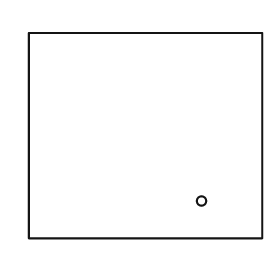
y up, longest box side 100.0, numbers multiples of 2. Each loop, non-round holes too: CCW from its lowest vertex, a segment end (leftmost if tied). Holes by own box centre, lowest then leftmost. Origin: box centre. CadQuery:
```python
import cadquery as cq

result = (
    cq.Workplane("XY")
    .moveTo(-50.0, -44.0)
    .lineTo(50.0, -44.0)
    .lineTo(50.0, 44.0)
    .lineTo(-50.0, 44.0)
    .close()
    .moveTo(24.0, -28.0)
    .circle(2.0)
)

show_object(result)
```